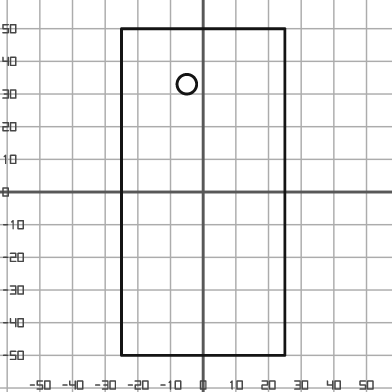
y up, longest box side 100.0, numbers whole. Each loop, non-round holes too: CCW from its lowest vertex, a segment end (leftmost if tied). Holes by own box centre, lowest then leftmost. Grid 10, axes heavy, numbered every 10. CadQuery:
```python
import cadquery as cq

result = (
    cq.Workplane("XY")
    .moveTo(-25.0, -50.0)
    .lineTo(25.0, -50.0)
    .lineTo(25.0, 50.0)
    .lineTo(-25.0, 50.0)
    .close()
    .moveTo(-5.0, 33.0)
    .circle(3.0)
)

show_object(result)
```